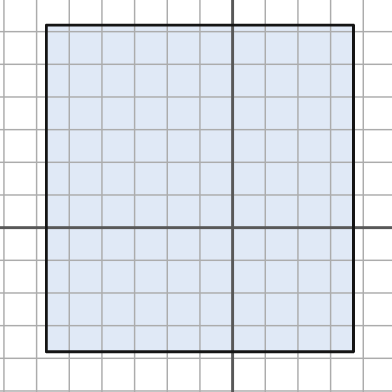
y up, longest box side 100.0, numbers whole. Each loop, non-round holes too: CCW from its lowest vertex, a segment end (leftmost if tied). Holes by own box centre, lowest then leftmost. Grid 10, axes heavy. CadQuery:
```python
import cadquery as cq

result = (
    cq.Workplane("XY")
    .moveTo(-57.0, -38.0)
    .lineTo(37.0, -38.0)
    .lineTo(37.0, 62.0)
    .lineTo(-57.0, 62.0)
    .close()
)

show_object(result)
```